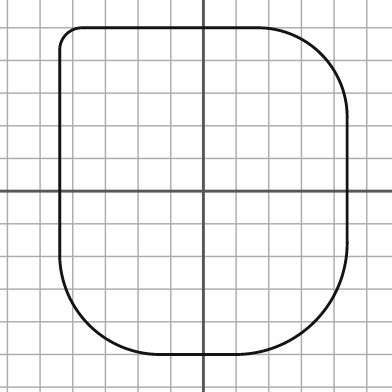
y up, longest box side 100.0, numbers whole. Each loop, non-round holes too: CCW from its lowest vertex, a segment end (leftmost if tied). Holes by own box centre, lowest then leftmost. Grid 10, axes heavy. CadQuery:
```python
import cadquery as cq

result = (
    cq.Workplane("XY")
    .moveTo(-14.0, -50.0)
    .lineTo(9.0, -50.0)
    .threePointArc((34.0, -40.0), (44.0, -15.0))
    .lineTo(44.0, 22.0)
    .threePointArc((36.0, 42.0), (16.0, 50.0))
    .lineTo(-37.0, 50.0)
    .threePointArc((-42.0, 48.0), (-44.0, 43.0))
    .lineTo(-44.0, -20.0)
    .threePointArc((-35.0, -41.0), (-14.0, -50.0))
    .close()
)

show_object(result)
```